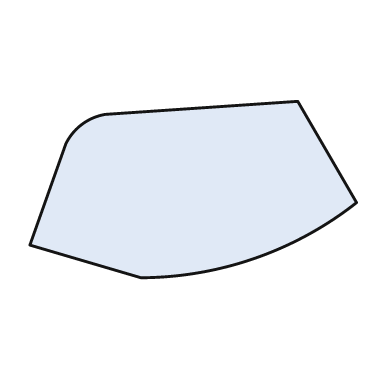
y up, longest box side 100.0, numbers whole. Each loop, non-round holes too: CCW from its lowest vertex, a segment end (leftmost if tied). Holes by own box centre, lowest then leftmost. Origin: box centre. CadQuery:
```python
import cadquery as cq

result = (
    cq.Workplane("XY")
    .moveTo(-16.0, -27.0)
    .threePointArc((19.0, -21.0), (50.0, -4.0))
    .lineTo(32.0, 27.0)
    .lineTo(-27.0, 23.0)
    .threePointArc((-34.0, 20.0), (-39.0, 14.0))
    .lineTo(-50.0, -17.0)
    .close()
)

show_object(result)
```